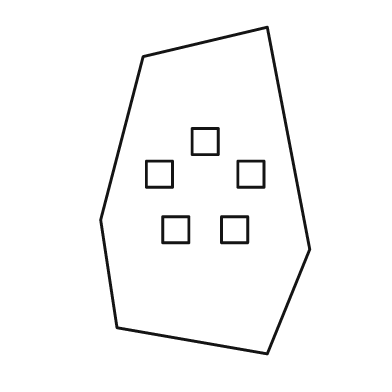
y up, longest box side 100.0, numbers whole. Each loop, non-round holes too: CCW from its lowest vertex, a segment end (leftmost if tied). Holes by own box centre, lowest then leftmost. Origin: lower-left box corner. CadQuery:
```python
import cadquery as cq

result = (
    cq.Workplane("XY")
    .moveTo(51.0, 0.0)
    .lineTo(64.0, 32.0)
    .lineTo(51.0, 100.0)
    .lineTo(13.0, 91.0)
    .lineTo(0.0, 41.0)
    .lineTo(5.0, 8.0)
    .close()
    .moveTo(19.0, 34.0)
    .lineTo(27.0, 34.0)
    .lineTo(27.0, 42.0)
    .lineTo(19.0, 42.0)
    .close()
    .moveTo(37.0, 34.0)
    .lineTo(45.0, 34.0)
    .lineTo(45.0, 42.0)
    .lineTo(37.0, 42.0)
    .close()
    .moveTo(14.0, 51.0)
    .lineTo(22.0, 51.0)
    .lineTo(22.0, 59.0)
    .lineTo(14.0, 59.0)
    .close()
    .moveTo(42.0, 51.0)
    .lineTo(50.0, 51.0)
    .lineTo(50.0, 59.0)
    .lineTo(42.0, 59.0)
    .close()
    .moveTo(28.0, 61.0)
    .lineTo(36.0, 61.0)
    .lineTo(36.0, 69.0)
    .lineTo(28.0, 69.0)
    .close()
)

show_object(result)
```